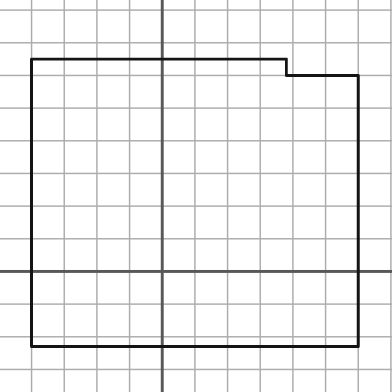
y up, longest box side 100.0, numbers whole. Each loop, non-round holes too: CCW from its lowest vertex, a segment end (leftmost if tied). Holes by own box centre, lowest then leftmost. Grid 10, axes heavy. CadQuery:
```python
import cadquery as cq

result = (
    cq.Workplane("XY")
    .moveTo(-40.0, -23.0)
    .lineTo(60.0, -23.0)
    .lineTo(60.0, 60.0)
    .lineTo(38.0, 60.0)
    .lineTo(38.0, 65.0)
    .lineTo(-40.0, 65.0)
    .close()
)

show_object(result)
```